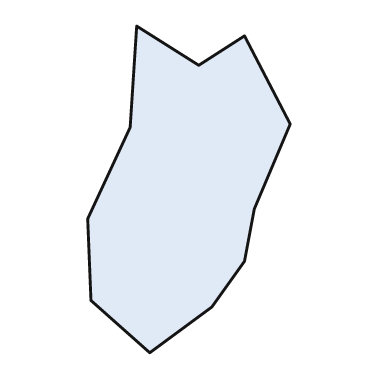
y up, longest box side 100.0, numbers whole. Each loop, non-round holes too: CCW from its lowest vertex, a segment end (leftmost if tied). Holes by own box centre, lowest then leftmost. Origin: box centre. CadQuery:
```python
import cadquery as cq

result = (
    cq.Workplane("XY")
    .moveTo(-12.0, -50.0)
    .lineTo(7.0, -36.0)
    .lineTo(17.0, -22.0)
    .lineTo(20.0, -6.0)
    .lineTo(31.0, 20.0)
    .lineTo(17.0, 47.0)
    .lineTo(3.0, 38.0)
    .lineTo(-16.0, 50.0)
    .lineTo(-18.0, 19.0)
    .lineTo(-31.0, -9.0)
    .lineTo(-30.0, -34.0)
    .close()
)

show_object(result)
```